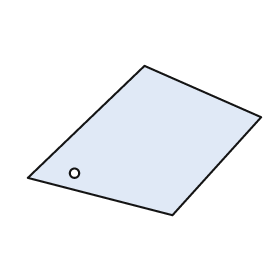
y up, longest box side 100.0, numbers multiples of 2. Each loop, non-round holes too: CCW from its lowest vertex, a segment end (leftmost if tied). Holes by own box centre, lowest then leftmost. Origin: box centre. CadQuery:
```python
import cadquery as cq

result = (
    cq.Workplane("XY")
    .moveTo(12.0, -32.0)
    .lineTo(50.0, 10.0)
    .lineTo(0.0, 32.0)
    .lineTo(-50.0, -16.0)
    .close()
    .moveTo(-30.0, -14.0)
    .circle(2.0)
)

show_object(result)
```